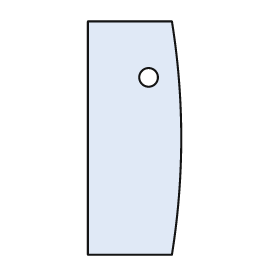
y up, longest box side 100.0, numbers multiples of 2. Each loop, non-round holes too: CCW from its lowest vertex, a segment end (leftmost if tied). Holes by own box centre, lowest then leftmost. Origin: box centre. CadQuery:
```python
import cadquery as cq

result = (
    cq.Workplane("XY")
    .moveTo(-20.0, -50.0)
    .lineTo(16.0, -50.0)
    .threePointArc((20.0, 0.0), (16.0, 50.0))
    .lineTo(-20.0, 50.0)
    .close()
    .moveTo(6.0, 26.0)
    .circle(4.0)
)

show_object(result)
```